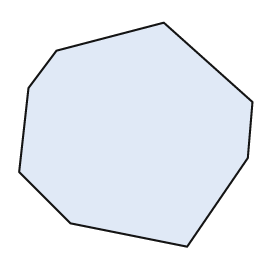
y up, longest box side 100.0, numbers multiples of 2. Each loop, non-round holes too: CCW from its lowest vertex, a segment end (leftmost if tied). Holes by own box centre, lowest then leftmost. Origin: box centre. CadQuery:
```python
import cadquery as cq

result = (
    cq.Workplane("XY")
    .moveTo(22.0, -48.0)
    .lineTo(48.0, -10.0)
    .lineTo(50.0, 14.0)
    .lineTo(12.0, 48.0)
    .lineTo(-34.0, 36.0)
    .lineTo(-46.0, 20.0)
    .lineTo(-50.0, -16.0)
    .lineTo(-28.0, -38.0)
    .close()
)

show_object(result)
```